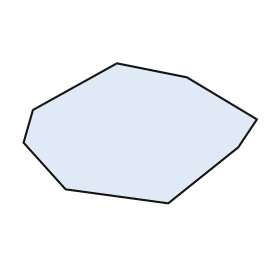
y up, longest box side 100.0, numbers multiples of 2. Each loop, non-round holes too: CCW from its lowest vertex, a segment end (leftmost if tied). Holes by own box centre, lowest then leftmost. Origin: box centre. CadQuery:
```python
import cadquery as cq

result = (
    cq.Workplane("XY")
    .moveTo(12.0, -30.0)
    .lineTo(42.0, -6.0)
    .lineTo(50.0, 6.0)
    .lineTo(20.0, 24.0)
    .lineTo(-10.0, 30.0)
    .lineTo(-46.0, 10.0)
    .lineTo(-50.0, -4.0)
    .lineTo(-32.0, -24.0)
    .close()
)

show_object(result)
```